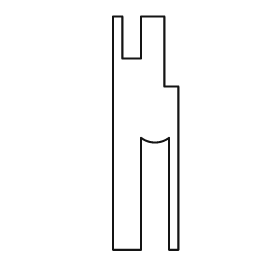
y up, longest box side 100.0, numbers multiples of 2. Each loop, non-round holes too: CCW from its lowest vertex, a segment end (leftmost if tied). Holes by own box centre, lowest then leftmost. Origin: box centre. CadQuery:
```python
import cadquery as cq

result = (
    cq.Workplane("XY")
    .moveTo(-14.0, -50.0)
    .lineTo(-2.0, -50.0)
    .lineTo(-2.0, -2.0)
    .threePointArc((4.0, -4.0), (10.0, -2.0))
    .lineTo(10.0, -50.0)
    .lineTo(14.0, -50.0)
    .lineTo(14.0, 20.0)
    .lineTo(8.0, 20.0)
    .lineTo(8.0, 50.0)
    .lineTo(-2.0, 50.0)
    .lineTo(-2.0, 32.0)
    .lineTo(-10.0, 32.0)
    .lineTo(-10.0, 50.0)
    .lineTo(-14.0, 50.0)
    .close()
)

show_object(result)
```